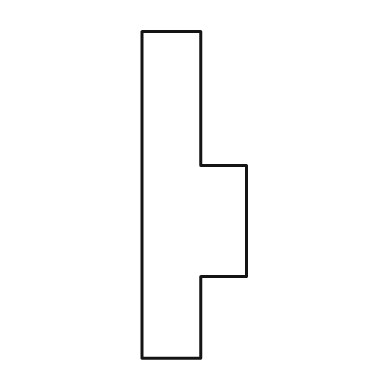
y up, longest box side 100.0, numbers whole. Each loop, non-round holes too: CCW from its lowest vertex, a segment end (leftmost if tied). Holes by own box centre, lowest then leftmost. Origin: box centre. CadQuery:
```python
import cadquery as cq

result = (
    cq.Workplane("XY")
    .moveTo(-16.0, -50.0)
    .lineTo(2.0, -50.0)
    .lineTo(2.0, -25.0)
    .lineTo(16.0, -25.0)
    .lineTo(16.0, 9.0)
    .lineTo(2.0, 9.0)
    .lineTo(2.0, 50.0)
    .lineTo(-16.0, 50.0)
    .close()
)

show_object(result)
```